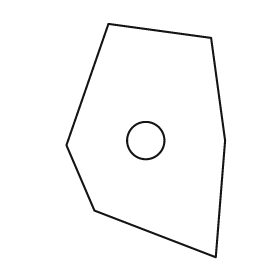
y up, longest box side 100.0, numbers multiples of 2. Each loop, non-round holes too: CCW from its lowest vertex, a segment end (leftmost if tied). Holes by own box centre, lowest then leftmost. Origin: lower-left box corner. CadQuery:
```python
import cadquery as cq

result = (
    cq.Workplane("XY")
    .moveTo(64.0, 0.0)
    .lineTo(68.0, 50.0)
    .lineTo(62.0, 94.0)
    .lineTo(18.0, 100.0)
    .lineTo(0.0, 48.0)
    .lineTo(12.0, 20.0)
    .close()
    .moveTo(34.0, 50.0)
    .circle(8.0)
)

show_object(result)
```